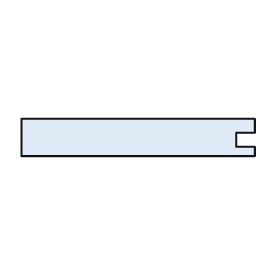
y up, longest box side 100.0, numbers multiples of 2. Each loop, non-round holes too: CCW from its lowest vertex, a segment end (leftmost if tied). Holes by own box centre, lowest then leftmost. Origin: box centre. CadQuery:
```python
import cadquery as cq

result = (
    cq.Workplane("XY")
    .moveTo(-50.0, -8.0)
    .lineTo(50.0, -8.0)
    .lineTo(50.0, -4.0)
    .lineTo(42.0, -4.0)
    .lineTo(42.0, 2.0)
    .lineTo(50.0, 2.0)
    .lineTo(50.0, 8.0)
    .lineTo(-50.0, 8.0)
    .close()
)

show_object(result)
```